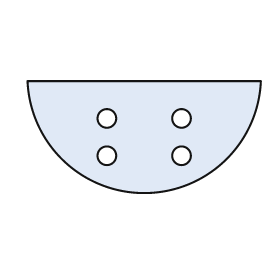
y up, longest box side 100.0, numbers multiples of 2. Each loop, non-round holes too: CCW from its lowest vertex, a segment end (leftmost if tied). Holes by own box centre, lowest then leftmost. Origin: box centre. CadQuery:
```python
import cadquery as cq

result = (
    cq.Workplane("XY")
    .moveTo(-50.0, 24.0)
    .threePointArc((0.0, -24.0), (50.0, 24.0))
    .close()
    .moveTo(-16.0, -8.0)
    .circle(4.0)
    .moveTo(16.0, -8.0)
    .circle(4.0)
    .moveTo(-16.0, 8.0)
    .circle(4.0)
    .moveTo(16.0, 8.0)
    .circle(4.0)
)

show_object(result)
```